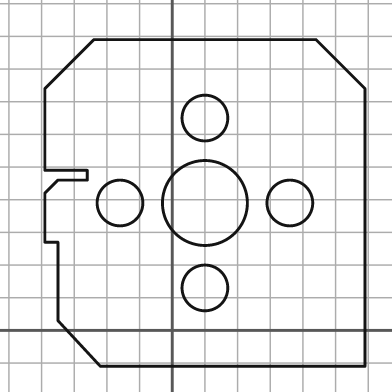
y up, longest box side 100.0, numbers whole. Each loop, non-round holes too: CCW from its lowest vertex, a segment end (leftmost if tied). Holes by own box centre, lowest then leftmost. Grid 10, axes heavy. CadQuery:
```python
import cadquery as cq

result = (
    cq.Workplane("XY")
    .moveTo(-22.0, -11.0)
    .lineTo(59.0, -11.0)
    .lineTo(59.0, 74.0)
    .lineTo(44.0, 89.0)
    .lineTo(-24.0, 89.0)
    .lineTo(-39.0, 74.0)
    .lineTo(-39.0, 49.0)
    .lineTo(-26.0, 49.0)
    .lineTo(-26.0, 46.0)
    .lineTo(-35.0, 46.0)
    .lineTo(-39.0, 42.0)
    .lineTo(-39.0, 27.0)
    .lineTo(-35.0, 27.0)
    .lineTo(-35.0, 3.0)
    .close()
    .moveTo(10.0, 13.0)
    .circle(7.0)
    .moveTo(-16.0, 39.0)
    .circle(7.0)
    .moveTo(10.0, 39.0)
    .circle(13.0)
    .moveTo(36.0, 39.0)
    .circle(7.0)
    .moveTo(10.0, 65.0)
    .circle(7.0)
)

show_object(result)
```